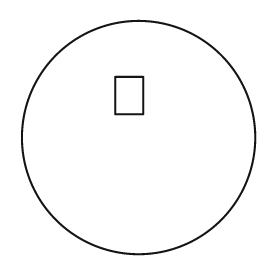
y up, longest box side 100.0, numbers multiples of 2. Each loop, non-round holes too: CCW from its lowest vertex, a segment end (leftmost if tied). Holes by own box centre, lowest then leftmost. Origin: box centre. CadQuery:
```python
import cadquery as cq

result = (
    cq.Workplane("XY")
    .moveTo(0.0, 0.0)
    .circle(50.0)
    .moveTo(-10.0, 10.0)
    .lineTo(2.0, 10.0)
    .lineTo(2.0, 26.0)
    .lineTo(-10.0, 26.0)
    .close()
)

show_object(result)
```